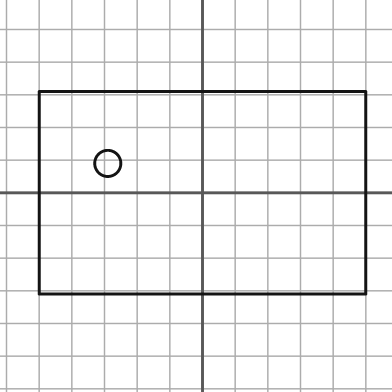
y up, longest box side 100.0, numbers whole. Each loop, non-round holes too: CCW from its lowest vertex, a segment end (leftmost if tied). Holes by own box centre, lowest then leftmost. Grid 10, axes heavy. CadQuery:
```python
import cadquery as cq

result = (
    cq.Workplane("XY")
    .moveTo(-50.0, -31.0)
    .lineTo(50.0, -31.0)
    .lineTo(50.0, 31.0)
    .lineTo(-50.0, 31.0)
    .close()
    .moveTo(-29.0, 9.0)
    .circle(4.0)
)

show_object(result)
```